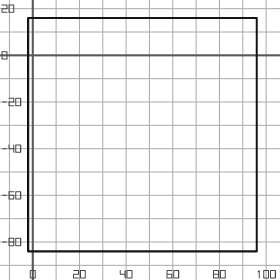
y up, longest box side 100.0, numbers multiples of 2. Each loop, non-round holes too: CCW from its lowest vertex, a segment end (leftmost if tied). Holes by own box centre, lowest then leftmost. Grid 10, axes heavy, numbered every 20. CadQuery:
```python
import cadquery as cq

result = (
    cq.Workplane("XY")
    .moveTo(-2.0, -84.0)
    .lineTo(96.0, -84.0)
    .lineTo(96.0, 16.0)
    .lineTo(-2.0, 16.0)
    .close()
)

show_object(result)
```